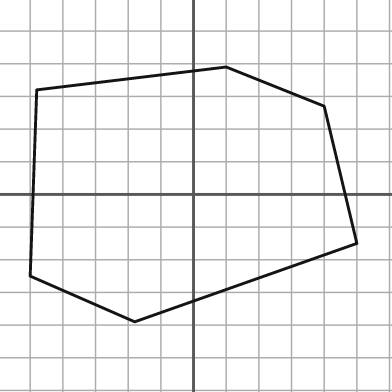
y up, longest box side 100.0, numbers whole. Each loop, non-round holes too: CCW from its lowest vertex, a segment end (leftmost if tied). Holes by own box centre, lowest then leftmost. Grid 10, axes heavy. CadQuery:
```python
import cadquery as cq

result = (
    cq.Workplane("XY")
    .moveTo(-18.0, -39.0)
    .lineTo(50.0, -15.0)
    .lineTo(40.0, 27.0)
    .lineTo(10.0, 39.0)
    .lineTo(-48.0, 32.0)
    .lineTo(-50.0, -25.0)
    .close()
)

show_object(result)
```